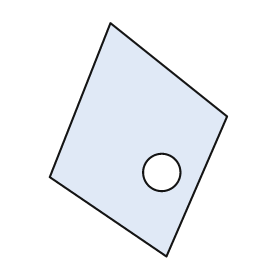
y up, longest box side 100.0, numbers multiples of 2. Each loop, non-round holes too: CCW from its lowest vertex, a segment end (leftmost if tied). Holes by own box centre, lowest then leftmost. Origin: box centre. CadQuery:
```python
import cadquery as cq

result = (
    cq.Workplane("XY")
    .moveTo(12.0, -50.0)
    .lineTo(38.0, 10.0)
    .lineTo(-12.0, 50.0)
    .lineTo(-38.0, -16.0)
    .close()
    .moveTo(10.0, -14.0)
    .circle(8.0)
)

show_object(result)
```